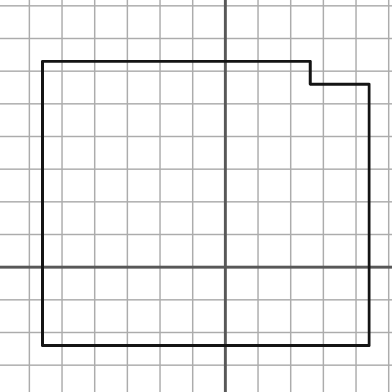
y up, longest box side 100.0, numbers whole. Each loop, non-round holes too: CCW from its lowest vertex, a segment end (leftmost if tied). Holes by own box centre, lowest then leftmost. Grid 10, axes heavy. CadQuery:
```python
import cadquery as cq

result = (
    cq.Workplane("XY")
    .moveTo(-56.0, -24.0)
    .lineTo(44.0, -24.0)
    .lineTo(44.0, 56.0)
    .lineTo(26.0, 56.0)
    .lineTo(26.0, 63.0)
    .lineTo(-56.0, 63.0)
    .close()
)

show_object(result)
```